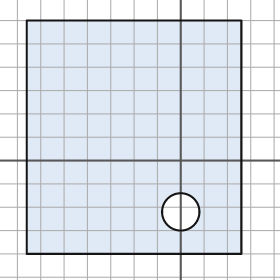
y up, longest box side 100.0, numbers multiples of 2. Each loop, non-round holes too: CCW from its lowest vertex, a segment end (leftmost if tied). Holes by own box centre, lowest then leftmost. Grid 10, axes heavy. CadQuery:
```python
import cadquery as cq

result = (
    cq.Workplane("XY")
    .moveTo(-66.0, -40.0)
    .lineTo(26.0, -40.0)
    .lineTo(26.0, 60.0)
    .lineTo(-66.0, 60.0)
    .close()
    .moveTo(0.0, -22.0)
    .circle(8.0)
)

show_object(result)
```